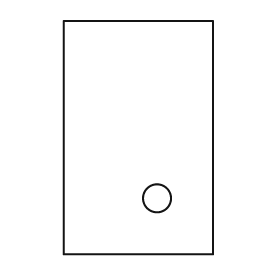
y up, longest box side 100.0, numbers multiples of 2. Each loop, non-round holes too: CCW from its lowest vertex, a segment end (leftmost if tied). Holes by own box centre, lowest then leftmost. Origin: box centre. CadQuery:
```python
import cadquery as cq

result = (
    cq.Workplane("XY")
    .moveTo(-32.0, -50.0)
    .lineTo(32.0, -50.0)
    .lineTo(32.0, 50.0)
    .lineTo(-32.0, 50.0)
    .close()
    .moveTo(8.0, -26.0)
    .circle(6.0)
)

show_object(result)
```